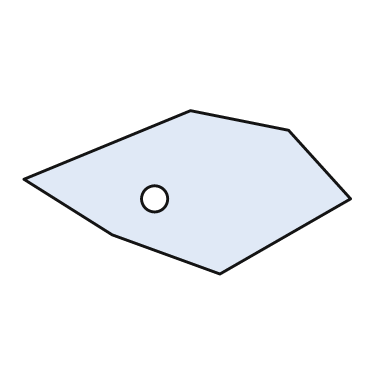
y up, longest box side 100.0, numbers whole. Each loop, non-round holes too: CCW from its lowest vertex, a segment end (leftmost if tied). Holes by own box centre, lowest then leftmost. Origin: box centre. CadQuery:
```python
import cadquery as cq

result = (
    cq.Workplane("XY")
    .moveTo(10.0, -25.0)
    .lineTo(50.0, -2.0)
    .lineTo(31.0, 19.0)
    .lineTo(1.0, 25.0)
    .lineTo(-50.0, 4.0)
    .lineTo(-23.0, -13.0)
    .close()
    .moveTo(-10.0, -2.0)
    .circle(4.0)
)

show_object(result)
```